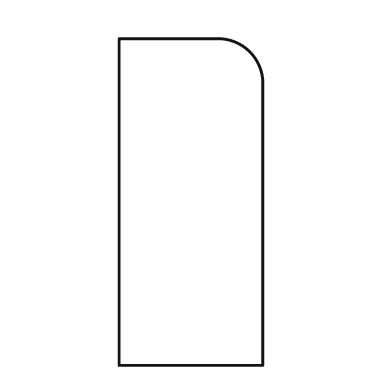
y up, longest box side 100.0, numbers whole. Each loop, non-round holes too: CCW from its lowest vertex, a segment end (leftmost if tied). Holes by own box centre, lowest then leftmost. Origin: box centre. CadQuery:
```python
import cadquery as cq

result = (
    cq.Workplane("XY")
    .moveTo(-22.0, -50.0)
    .lineTo(22.0, -50.0)
    .lineTo(22.0, 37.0)
    .threePointArc((18.0, 46.0), (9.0, 50.0))
    .lineTo(-22.0, 50.0)
    .close()
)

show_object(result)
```